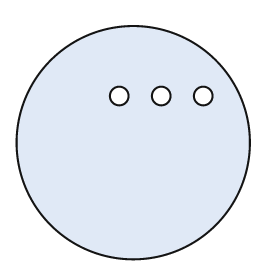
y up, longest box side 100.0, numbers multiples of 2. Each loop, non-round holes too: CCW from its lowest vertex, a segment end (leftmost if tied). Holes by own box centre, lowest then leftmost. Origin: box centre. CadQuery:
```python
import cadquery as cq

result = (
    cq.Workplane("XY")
    .moveTo(0.0, 0.0)
    .circle(50.0)
    .moveTo(-6.0, 20.0)
    .circle(4.0)
    .moveTo(12.0, 20.0)
    .circle(4.0)
    .moveTo(30.0, 20.0)
    .circle(4.0)
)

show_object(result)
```